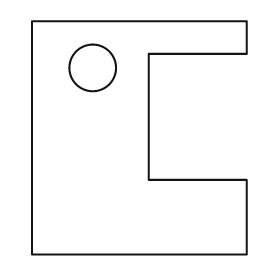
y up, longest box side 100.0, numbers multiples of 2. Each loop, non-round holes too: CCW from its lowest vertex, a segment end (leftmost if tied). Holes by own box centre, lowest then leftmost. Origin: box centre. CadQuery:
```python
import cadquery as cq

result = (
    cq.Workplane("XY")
    .moveTo(-46.0, -50.0)
    .lineTo(46.0, -50.0)
    .lineTo(46.0, -18.0)
    .lineTo(4.0, -18.0)
    .lineTo(4.0, 36.0)
    .lineTo(46.0, 36.0)
    .lineTo(46.0, 50.0)
    .lineTo(-46.0, 50.0)
    .close()
    .moveTo(-20.0, 30.0)
    .circle(10.0)
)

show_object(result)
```